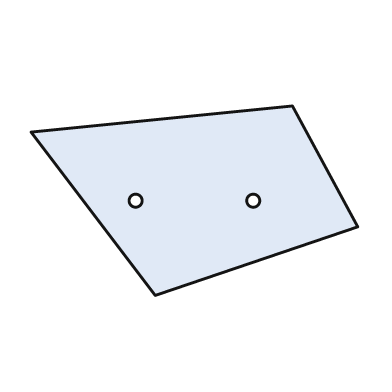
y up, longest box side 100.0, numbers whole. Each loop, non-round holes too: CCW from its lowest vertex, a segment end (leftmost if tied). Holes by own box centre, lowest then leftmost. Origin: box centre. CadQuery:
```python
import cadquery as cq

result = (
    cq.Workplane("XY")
    .moveTo(-12.0, -29.0)
    .lineTo(50.0, -8.0)
    .lineTo(30.0, 29.0)
    .lineTo(-50.0, 21.0)
    .close()
    .moveTo(-18.0, 0.0)
    .circle(2.0)
    .moveTo(18.0, 0.0)
    .circle(2.0)
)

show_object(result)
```